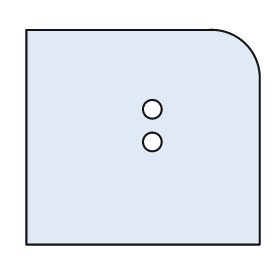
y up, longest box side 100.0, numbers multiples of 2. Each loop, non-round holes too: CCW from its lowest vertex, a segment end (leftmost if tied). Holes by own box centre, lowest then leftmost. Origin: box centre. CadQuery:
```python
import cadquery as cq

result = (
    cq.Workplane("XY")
    .moveTo(-50.0, -46.0)
    .lineTo(50.0, -46.0)
    .lineTo(50.0, 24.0)
    .threePointArc((44.0, 40.0), (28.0, 46.0))
    .lineTo(-50.0, 46.0)
    .close()
    .moveTo(4.0, -2.0)
    .circle(4.0)
    .moveTo(4.0, 12.0)
    .circle(4.0)
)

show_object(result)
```